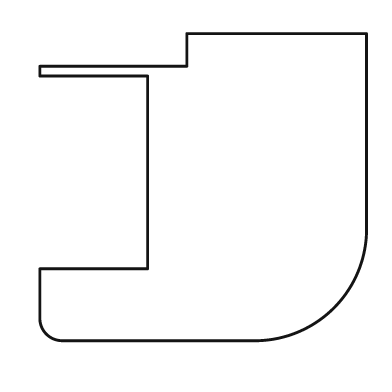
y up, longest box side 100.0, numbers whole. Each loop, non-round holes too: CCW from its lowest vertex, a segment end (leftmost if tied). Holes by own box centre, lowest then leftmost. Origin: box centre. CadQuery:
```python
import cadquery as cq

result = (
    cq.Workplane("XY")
    .moveTo(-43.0, -47.0)
    .lineTo(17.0, -47.0)
    .threePointArc((40.0, -37.0), (50.0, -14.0))
    .lineTo(50.0, 47.0)
    .lineTo(-5.0, 47.0)
    .lineTo(-5.0, 37.0)
    .lineTo(-50.0, 37.0)
    .lineTo(-50.0, 34.0)
    .lineTo(-17.0, 34.0)
    .lineTo(-17.0, -25.0)
    .lineTo(-50.0, -25.0)
    .lineTo(-50.0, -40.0)
    .threePointArc((-48.0, -45.0), (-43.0, -47.0))
    .close()
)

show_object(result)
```